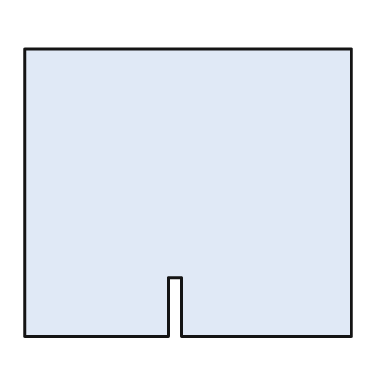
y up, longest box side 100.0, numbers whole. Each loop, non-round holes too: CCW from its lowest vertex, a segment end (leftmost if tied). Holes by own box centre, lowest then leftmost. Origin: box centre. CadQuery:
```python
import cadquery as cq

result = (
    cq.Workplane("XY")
    .moveTo(-50.0, -44.0)
    .lineTo(-6.0, -44.0)
    .lineTo(-6.0, -26.0)
    .lineTo(-2.0, -26.0)
    .lineTo(-2.0, -44.0)
    .lineTo(50.0, -44.0)
    .lineTo(50.0, 44.0)
    .lineTo(-50.0, 44.0)
    .close()
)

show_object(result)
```